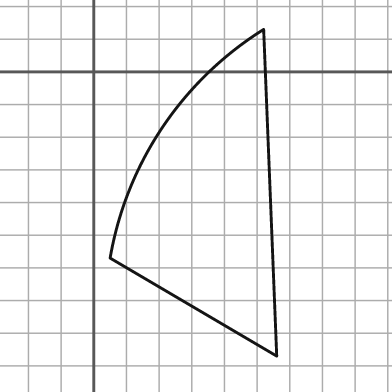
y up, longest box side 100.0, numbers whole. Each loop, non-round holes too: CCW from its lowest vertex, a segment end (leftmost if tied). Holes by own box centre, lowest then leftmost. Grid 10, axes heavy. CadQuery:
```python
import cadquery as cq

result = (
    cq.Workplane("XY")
    .moveTo(56.0, -87.0)
    .lineTo(52.0, 13.0)
    .threePointArc((21.0, -17.0), (5.0, -57.0))
    .close()
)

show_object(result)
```